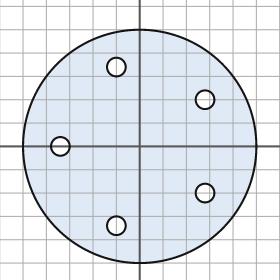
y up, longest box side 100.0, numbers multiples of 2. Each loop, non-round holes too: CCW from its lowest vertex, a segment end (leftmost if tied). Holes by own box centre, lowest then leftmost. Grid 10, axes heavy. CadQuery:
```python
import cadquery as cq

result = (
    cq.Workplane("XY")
    .moveTo(0.0, 0.0)
    .circle(50.0)
    .moveTo(-10.0, -34.0)
    .circle(4.0)
    .moveTo(28.0, -20.0)
    .circle(4.0)
    .moveTo(-34.0, 0.0)
    .circle(4.0)
    .moveTo(28.0, 20.0)
    .circle(4.0)
    .moveTo(-10.0, 34.0)
    .circle(4.0)
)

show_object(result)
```